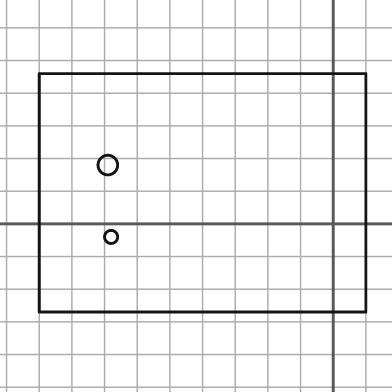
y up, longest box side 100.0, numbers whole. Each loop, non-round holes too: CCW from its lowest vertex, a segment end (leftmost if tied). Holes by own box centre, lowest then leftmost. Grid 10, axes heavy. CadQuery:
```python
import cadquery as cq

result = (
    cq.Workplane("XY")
    .moveTo(-90.0, -27.0)
    .lineTo(10.0, -27.0)
    .lineTo(10.0, 46.0)
    .lineTo(-90.0, 46.0)
    .close()
    .moveTo(-68.0, -4.0)
    .circle(2.0)
    .moveTo(-69.0, 18.0)
    .circle(3.0)
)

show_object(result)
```